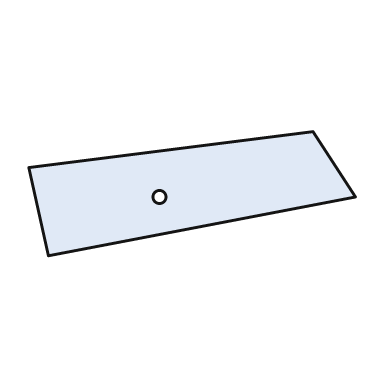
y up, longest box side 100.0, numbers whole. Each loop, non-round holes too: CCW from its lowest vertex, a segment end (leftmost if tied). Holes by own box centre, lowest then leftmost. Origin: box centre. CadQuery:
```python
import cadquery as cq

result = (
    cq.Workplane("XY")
    .moveTo(-44.0, -19.0)
    .lineTo(50.0, -1.0)
    .lineTo(37.0, 19.0)
    .lineTo(-50.0, 8.0)
    .close()
    .moveTo(-10.0, -1.0)
    .circle(2.0)
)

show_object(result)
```